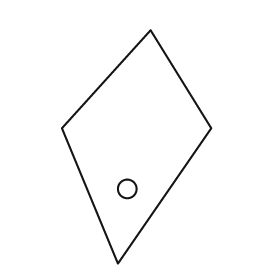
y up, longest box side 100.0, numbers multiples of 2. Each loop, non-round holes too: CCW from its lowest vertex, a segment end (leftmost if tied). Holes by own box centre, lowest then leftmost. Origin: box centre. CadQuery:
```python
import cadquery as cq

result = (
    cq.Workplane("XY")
    .moveTo(-8.0, -50.0)
    .lineTo(32.0, 8.0)
    .lineTo(6.0, 50.0)
    .lineTo(-32.0, 8.0)
    .close()
    .moveTo(-4.0, -18.0)
    .circle(4.0)
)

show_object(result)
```